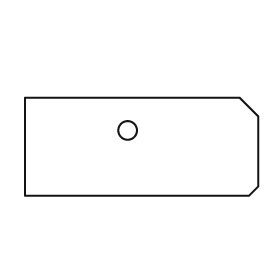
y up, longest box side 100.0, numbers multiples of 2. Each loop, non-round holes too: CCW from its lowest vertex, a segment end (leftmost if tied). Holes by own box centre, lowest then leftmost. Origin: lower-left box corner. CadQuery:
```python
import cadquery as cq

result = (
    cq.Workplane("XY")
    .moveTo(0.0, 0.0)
    .lineTo(96.0, 0.0)
    .lineTo(100.0, 4.0)
    .lineTo(100.0, 34.0)
    .lineTo(92.0, 42.0)
    .lineTo(0.0, 42.0)
    .close()
    .moveTo(44.0, 28.0)
    .circle(4.0)
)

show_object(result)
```